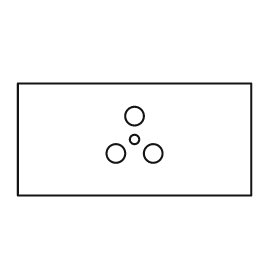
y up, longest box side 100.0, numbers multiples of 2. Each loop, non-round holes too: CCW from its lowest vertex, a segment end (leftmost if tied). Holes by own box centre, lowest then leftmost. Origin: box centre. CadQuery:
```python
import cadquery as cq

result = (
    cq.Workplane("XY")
    .moveTo(-50.0, -24.0)
    .lineTo(50.0, -24.0)
    .lineTo(50.0, 24.0)
    .lineTo(-50.0, 24.0)
    .close()
    .moveTo(-8.0, -6.0)
    .circle(4.0)
    .moveTo(8.0, -6.0)
    .circle(4.0)
    .moveTo(0.0, 0.0)
    .circle(2.0)
    .moveTo(0.0, 10.0)
    .circle(4.0)
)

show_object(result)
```